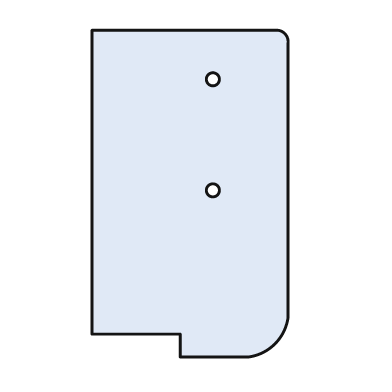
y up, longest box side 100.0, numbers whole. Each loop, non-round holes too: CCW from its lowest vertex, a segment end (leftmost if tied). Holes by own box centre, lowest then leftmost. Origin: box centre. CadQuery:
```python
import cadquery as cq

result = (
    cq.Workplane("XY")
    .moveTo(-3.0, -50.0)
    .lineTo(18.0, -50.0)
    .threePointArc((26.0, -46.0), (30.0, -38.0))
    .lineTo(30.0, 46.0)
    .threePointArc((29.0, 49.0), (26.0, 50.0))
    .lineTo(-30.0, 50.0)
    .lineTo(-30.0, -43.0)
    .lineTo(-3.0, -43.0)
    .close()
    .moveTo(7.0, 1.0)
    .circle(2.0)
    .moveTo(7.0, 35.0)
    .circle(2.0)
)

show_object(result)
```